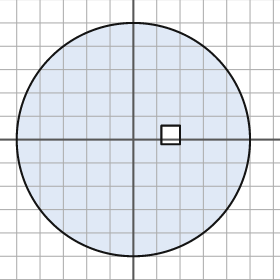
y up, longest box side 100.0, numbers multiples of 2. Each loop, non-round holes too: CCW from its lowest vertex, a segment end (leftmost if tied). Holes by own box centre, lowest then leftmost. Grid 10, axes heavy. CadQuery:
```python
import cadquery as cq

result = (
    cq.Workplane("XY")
    .moveTo(0.0, 0.0)
    .circle(50.0)
    .moveTo(12.0, -2.0)
    .lineTo(20.0, -2.0)
    .lineTo(20.0, 6.0)
    .lineTo(12.0, 6.0)
    .close()
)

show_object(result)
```